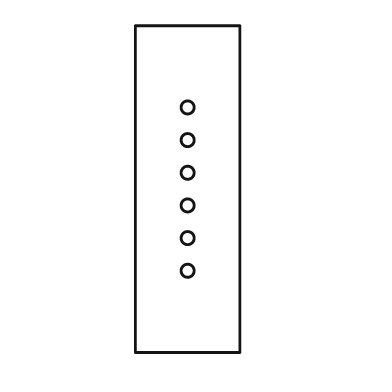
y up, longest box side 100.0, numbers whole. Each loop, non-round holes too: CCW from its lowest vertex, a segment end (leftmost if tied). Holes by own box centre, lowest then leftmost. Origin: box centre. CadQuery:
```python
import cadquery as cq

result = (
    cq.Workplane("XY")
    .moveTo(-16.0, -50.0)
    .lineTo(16.0, -50.0)
    .lineTo(16.0, 50.0)
    .lineTo(-16.0, 50.0)
    .close()
    .moveTo(0.0, -25.0)
    .circle(2.0)
    .moveTo(0.0, -15.0)
    .circle(2.0)
    .moveTo(0.0, -5.0)
    .circle(2.0)
    .moveTo(0.0, 5.0)
    .circle(2.0)
    .moveTo(0.0, 15.0)
    .circle(2.0)
    .moveTo(0.0, 25.0)
    .circle(2.0)
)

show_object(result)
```